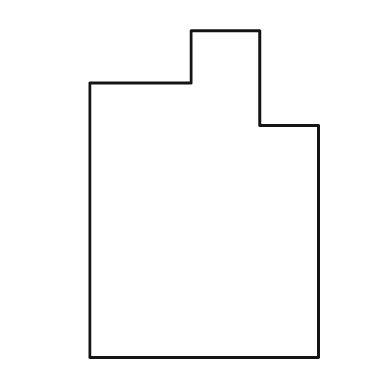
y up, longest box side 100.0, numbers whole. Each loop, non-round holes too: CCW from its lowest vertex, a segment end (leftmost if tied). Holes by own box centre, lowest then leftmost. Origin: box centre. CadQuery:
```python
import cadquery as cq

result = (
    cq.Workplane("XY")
    .moveTo(-35.0, -50.0)
    .lineTo(35.0, -50.0)
    .lineTo(35.0, 21.0)
    .lineTo(17.0, 21.0)
    .lineTo(17.0, 50.0)
    .lineTo(-4.0, 50.0)
    .lineTo(-4.0, 34.0)
    .lineTo(-35.0, 34.0)
    .close()
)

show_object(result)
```